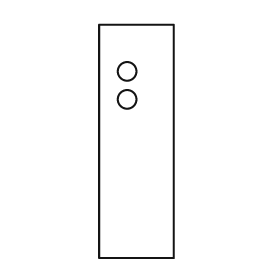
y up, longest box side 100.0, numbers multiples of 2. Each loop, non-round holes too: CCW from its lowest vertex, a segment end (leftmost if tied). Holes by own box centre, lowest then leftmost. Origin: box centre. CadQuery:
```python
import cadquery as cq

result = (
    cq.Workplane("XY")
    .moveTo(-16.0, -50.0)
    .lineTo(16.0, -50.0)
    .lineTo(16.0, 50.0)
    .lineTo(-16.0, 50.0)
    .close()
    .moveTo(-4.0, 18.0)
    .circle(4.0)
    .moveTo(-4.0, 30.0)
    .circle(4.0)
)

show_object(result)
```